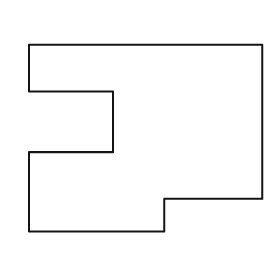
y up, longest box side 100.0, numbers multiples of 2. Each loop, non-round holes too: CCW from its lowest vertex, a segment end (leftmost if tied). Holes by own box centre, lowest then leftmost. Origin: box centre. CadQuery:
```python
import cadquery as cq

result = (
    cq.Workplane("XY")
    .moveTo(-50.0, -40.0)
    .lineTo(8.0, -40.0)
    .lineTo(8.0, -26.0)
    .lineTo(50.0, -26.0)
    .lineTo(50.0, 40.0)
    .lineTo(-50.0, 40.0)
    .lineTo(-50.0, 20.0)
    .lineTo(-14.0, 20.0)
    .lineTo(-14.0, -6.0)
    .lineTo(-50.0, -6.0)
    .close()
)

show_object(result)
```